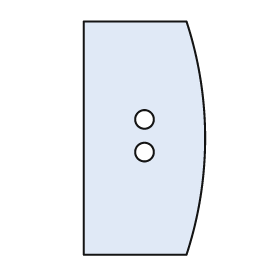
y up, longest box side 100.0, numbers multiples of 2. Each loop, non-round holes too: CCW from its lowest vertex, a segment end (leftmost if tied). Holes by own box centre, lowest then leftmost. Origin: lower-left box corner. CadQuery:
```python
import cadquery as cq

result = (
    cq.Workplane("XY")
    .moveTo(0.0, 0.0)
    .lineTo(44.0, 0.0)
    .threePointArc((52.0, 50.0), (44.0, 100.0))
    .lineTo(0.0, 100.0)
    .close()
    .moveTo(26.0, 44.0)
    .circle(4.0)
    .moveTo(26.0, 58.0)
    .circle(4.0)
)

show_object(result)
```